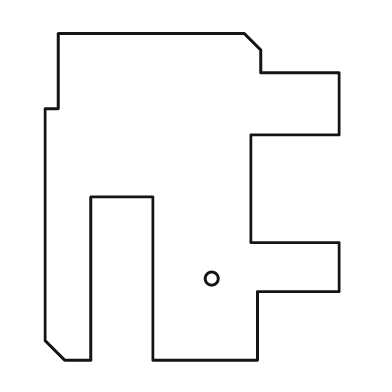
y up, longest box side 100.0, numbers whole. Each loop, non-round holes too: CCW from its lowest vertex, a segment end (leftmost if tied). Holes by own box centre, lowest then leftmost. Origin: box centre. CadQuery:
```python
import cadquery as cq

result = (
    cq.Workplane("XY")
    .moveTo(-39.0, -50.0)
    .lineTo(-31.0, -50.0)
    .lineTo(-31.0, 0.0)
    .lineTo(-12.0, 0.0)
    .lineTo(-12.0, -50.0)
    .lineTo(20.0, -50.0)
    .lineTo(20.0, -29.0)
    .lineTo(45.0, -29.0)
    .lineTo(45.0, -14.0)
    .lineTo(18.0, -14.0)
    .lineTo(18.0, 19.0)
    .lineTo(45.0, 19.0)
    .lineTo(45.0, 38.0)
    .lineTo(21.0, 38.0)
    .lineTo(21.0, 45.0)
    .lineTo(16.0, 50.0)
    .lineTo(-41.0, 50.0)
    .lineTo(-41.0, 27.0)
    .lineTo(-45.0, 27.0)
    .lineTo(-45.0, -44.0)
    .close()
    .moveTo(6.0, -25.0)
    .circle(2.0)
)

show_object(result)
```